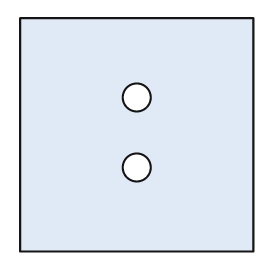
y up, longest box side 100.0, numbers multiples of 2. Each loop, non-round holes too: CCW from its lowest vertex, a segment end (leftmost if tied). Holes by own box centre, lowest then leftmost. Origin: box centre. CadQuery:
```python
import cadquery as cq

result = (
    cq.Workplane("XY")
    .moveTo(-50.0, -50.0)
    .lineTo(50.0, -50.0)
    .lineTo(50.0, 50.0)
    .lineTo(-50.0, 50.0)
    .close()
    .moveTo(0.0, -14.0)
    .circle(6.0)
    .moveTo(0.0, 16.0)
    .circle(6.0)
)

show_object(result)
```